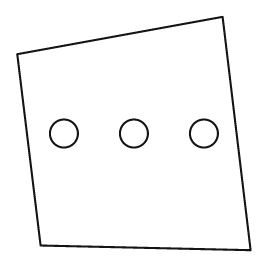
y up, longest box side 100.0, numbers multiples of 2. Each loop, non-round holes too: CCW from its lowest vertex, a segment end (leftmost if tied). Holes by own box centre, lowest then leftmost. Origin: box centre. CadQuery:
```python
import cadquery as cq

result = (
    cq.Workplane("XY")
    .moveTo(50.0, -50.0)
    .lineTo(38.0, 50.0)
    .lineTo(-50.0, 34.0)
    .lineTo(-40.0, -48.0)
    .close()
    .moveTo(-30.0, 0.0)
    .circle(6.0)
    .moveTo(0.0, 0.0)
    .circle(6.0)
    .moveTo(30.0, 0.0)
    .circle(6.0)
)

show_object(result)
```